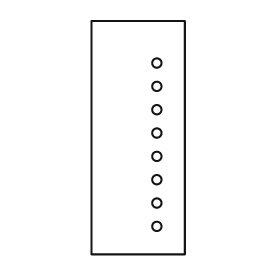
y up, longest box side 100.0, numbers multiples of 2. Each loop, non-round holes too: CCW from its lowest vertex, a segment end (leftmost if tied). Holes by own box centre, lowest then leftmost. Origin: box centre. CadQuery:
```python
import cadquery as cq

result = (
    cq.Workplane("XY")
    .moveTo(-20.0, -50.0)
    .lineTo(20.0, -50.0)
    .lineTo(20.0, 50.0)
    .lineTo(-20.0, 50.0)
    .close()
    .moveTo(8.0, -38.0)
    .circle(2.0)
    .moveTo(8.0, -28.0)
    .circle(2.0)
    .moveTo(8.0, -18.0)
    .circle(2.0)
    .moveTo(8.0, -8.0)
    .circle(2.0)
    .moveTo(8.0, 2.0)
    .circle(2.0)
    .moveTo(8.0, 12.0)
    .circle(2.0)
    .moveTo(8.0, 22.0)
    .circle(2.0)
    .moveTo(8.0, 32.0)
    .circle(2.0)
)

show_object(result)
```